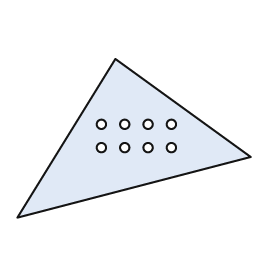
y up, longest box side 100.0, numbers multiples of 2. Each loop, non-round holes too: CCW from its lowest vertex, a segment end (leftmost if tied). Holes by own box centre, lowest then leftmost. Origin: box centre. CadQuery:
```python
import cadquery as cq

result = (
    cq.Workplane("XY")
    .moveTo(-50.0, -34.0)
    .lineTo(50.0, -8.0)
    .lineTo(-8.0, 34.0)
    .close()
    .moveTo(-14.0, -4.0)
    .circle(2.0)
    .moveTo(-4.0, -4.0)
    .circle(2.0)
    .moveTo(6.0, -4.0)
    .circle(2.0)
    .moveTo(16.0, -4.0)
    .circle(2.0)
    .moveTo(-14.0, 6.0)
    .circle(2.0)
    .moveTo(-4.0, 6.0)
    .circle(2.0)
    .moveTo(6.0, 6.0)
    .circle(2.0)
    .moveTo(16.0, 6.0)
    .circle(2.0)
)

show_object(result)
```